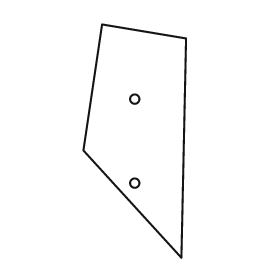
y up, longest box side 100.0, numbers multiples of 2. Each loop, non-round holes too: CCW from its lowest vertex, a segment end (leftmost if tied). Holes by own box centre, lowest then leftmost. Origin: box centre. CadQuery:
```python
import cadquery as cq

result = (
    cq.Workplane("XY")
    .moveTo(20.0, -50.0)
    .lineTo(22.0, 44.0)
    .lineTo(-14.0, 50.0)
    .lineTo(-22.0, -4.0)
    .close()
    .moveTo(0.0, -18.0)
    .circle(2.0)
    .moveTo(0.0, 18.0)
    .circle(2.0)
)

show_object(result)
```